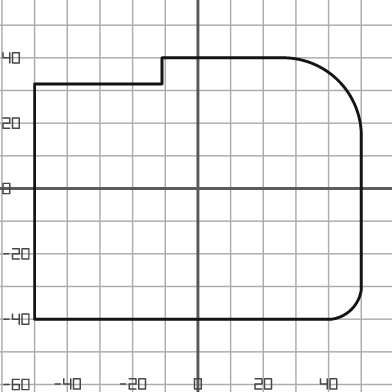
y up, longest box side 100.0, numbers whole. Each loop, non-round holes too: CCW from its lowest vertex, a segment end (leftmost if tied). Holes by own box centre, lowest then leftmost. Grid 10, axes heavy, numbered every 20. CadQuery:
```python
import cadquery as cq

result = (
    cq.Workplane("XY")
    .moveTo(-50.0, -40.0)
    .lineTo(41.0, -40.0)
    .threePointArc((47.0, -37.0), (50.0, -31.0))
    .lineTo(50.0, 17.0)
    .threePointArc((43.0, 33.0), (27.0, 40.0))
    .lineTo(-11.0, 40.0)
    .lineTo(-11.0, 32.0)
    .lineTo(-50.0, 32.0)
    .close()
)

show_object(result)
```